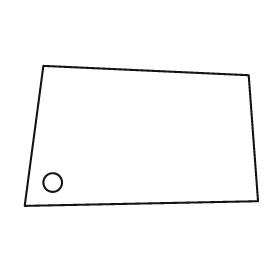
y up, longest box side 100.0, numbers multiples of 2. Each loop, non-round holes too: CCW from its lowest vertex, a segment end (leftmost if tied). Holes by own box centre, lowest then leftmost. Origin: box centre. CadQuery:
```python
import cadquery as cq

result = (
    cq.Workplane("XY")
    .moveTo(-50.0, -30.0)
    .lineTo(50.0, -28.0)
    .lineTo(46.0, 26.0)
    .lineTo(-42.0, 30.0)
    .close()
    .moveTo(-38.0, -20.0)
    .circle(4.0)
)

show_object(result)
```